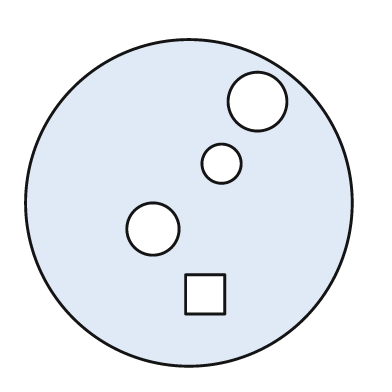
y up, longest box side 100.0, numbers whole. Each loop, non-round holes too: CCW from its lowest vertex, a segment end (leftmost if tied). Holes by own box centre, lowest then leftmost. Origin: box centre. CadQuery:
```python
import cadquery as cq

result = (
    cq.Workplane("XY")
    .moveTo(0.0, 0.0)
    .circle(50.0)
    .moveTo(-1.0, -34.0)
    .lineTo(11.0, -34.0)
    .lineTo(11.0, -22.0)
    .lineTo(-1.0, -22.0)
    .close()
    .moveTo(-11.0, -8.0)
    .circle(8.0)
    .moveTo(10.0, 12.0)
    .circle(6.0)
    .moveTo(21.0, 31.0)
    .circle(9.0)
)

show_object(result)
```